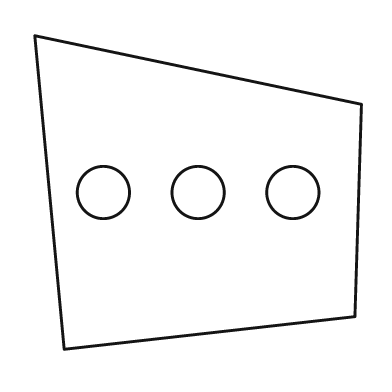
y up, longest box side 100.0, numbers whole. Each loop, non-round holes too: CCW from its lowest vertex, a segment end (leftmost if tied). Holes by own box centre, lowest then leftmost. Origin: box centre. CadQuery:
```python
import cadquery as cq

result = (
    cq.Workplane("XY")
    .moveTo(-41.0, -48.0)
    .lineTo(48.0, -38.0)
    .lineTo(50.0, 27.0)
    .lineTo(-50.0, 48.0)
    .close()
    .moveTo(-29.0, 0.0)
    .circle(8.0)
    .moveTo(0.0, 0.0)
    .circle(8.0)
    .moveTo(29.0, 0.0)
    .circle(8.0)
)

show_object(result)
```